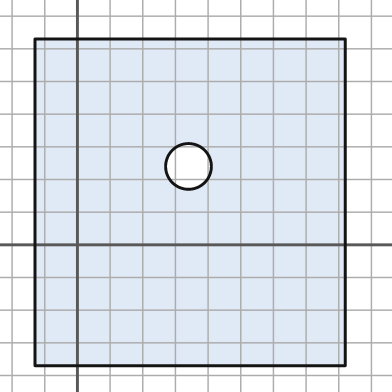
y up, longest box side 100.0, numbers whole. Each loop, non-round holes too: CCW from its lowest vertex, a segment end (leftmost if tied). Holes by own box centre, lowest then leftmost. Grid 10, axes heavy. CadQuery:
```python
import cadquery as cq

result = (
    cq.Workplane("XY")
    .moveTo(-13.0, -37.0)
    .lineTo(82.0, -37.0)
    .lineTo(82.0, 63.0)
    .lineTo(-13.0, 63.0)
    .close()
    .moveTo(34.0, 24.0)
    .circle(7.0)
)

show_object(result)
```